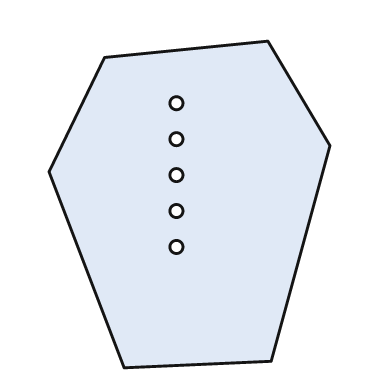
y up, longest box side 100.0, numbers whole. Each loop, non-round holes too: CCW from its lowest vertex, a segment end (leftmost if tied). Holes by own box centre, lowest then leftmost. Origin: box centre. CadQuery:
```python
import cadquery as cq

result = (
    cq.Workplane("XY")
    .moveTo(-20.0, -50.0)
    .lineTo(25.0, -48.0)
    .lineTo(43.0, 18.0)
    .lineTo(24.0, 50.0)
    .lineTo(-26.0, 45.0)
    .lineTo(-43.0, 10.0)
    .close()
    .moveTo(-4.0, -13.0)
    .circle(2.0)
    .moveTo(-4.0, -2.0)
    .circle(2.0)
    .moveTo(-4.0, 9.0)
    .circle(2.0)
    .moveTo(-4.0, 20.0)
    .circle(2.0)
    .moveTo(-4.0, 31.0)
    .circle(2.0)
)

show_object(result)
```